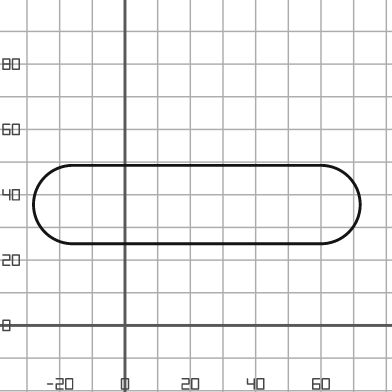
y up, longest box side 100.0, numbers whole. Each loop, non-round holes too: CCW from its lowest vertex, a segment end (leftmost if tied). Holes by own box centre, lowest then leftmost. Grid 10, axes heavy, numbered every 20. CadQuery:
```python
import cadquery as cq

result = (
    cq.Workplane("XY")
    .moveTo(-16.0, 25.0)
    .lineTo(60.0, 25.0)
    .threePointArc((72.0, 37.0), (60.0, 49.0))
    .lineTo(-16.0, 49.0)
    .threePointArc((-28.0, 37.0), (-16.0, 25.0))
    .close()
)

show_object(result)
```